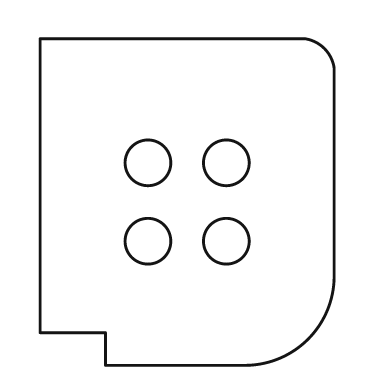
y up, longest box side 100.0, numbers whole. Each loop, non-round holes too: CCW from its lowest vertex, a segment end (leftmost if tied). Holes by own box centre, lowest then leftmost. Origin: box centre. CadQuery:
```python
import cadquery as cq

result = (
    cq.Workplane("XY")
    .moveTo(-25.0, -50.0)
    .lineTo(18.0, -50.0)
    .threePointArc((37.0, -42.0), (45.0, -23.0))
    .lineTo(45.0, 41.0)
    .threePointArc((42.0, 47.0), (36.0, 50.0))
    .lineTo(-45.0, 50.0)
    .lineTo(-45.0, -40.0)
    .lineTo(-25.0, -40.0)
    .close()
    .moveTo(-12.0, -12.0)
    .circle(7.0)
    .moveTo(12.0, -12.0)
    .circle(7.0)
    .moveTo(-12.0, 12.0)
    .circle(7.0)
    .moveTo(12.0, 12.0)
    .circle(7.0)
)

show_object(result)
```